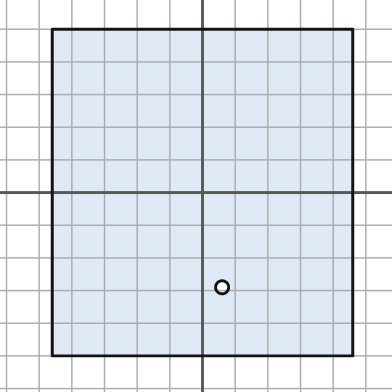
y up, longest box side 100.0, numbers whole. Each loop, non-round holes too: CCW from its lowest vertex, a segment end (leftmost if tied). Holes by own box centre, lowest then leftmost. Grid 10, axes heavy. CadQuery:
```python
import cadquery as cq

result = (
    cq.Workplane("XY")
    .moveTo(-46.0, -50.0)
    .lineTo(46.0, -50.0)
    .lineTo(46.0, 50.0)
    .lineTo(-46.0, 50.0)
    .close()
    .moveTo(6.0, -29.0)
    .circle(2.0)
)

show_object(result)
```